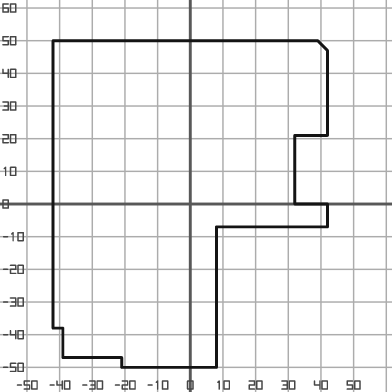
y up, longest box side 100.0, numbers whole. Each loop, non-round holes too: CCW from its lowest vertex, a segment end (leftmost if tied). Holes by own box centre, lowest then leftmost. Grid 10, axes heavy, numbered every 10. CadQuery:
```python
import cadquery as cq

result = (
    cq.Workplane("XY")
    .moveTo(-21.0, -50.0)
    .lineTo(8.0, -50.0)
    .lineTo(8.0, -7.0)
    .lineTo(42.0, -7.0)
    .lineTo(42.0, 0.0)
    .lineTo(32.0, 0.0)
    .lineTo(32.0, 21.0)
    .lineTo(42.0, 21.0)
    .lineTo(42.0, 47.0)
    .lineTo(39.0, 50.0)
    .lineTo(-42.0, 50.0)
    .lineTo(-42.0, -38.0)
    .lineTo(-39.0, -38.0)
    .lineTo(-39.0, -47.0)
    .lineTo(-21.0, -47.0)
    .close()
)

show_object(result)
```